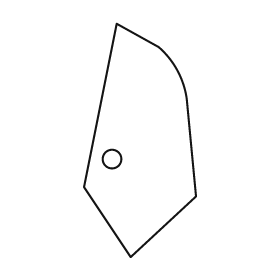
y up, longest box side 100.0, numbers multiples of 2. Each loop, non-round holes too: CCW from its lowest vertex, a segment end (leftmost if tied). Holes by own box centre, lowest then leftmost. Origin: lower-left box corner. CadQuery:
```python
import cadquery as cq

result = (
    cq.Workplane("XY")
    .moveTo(20.0, 0.0)
    .lineTo(48.0, 26.0)
    .lineTo(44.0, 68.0)
    .threePointArc((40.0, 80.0), (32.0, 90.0))
    .lineTo(14.0, 100.0)
    .lineTo(0.0, 30.0)
    .close()
    .moveTo(12.0, 42.0)
    .circle(4.0)
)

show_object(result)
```